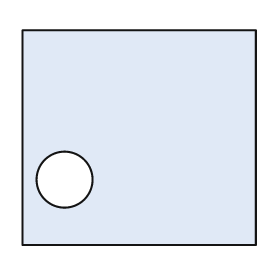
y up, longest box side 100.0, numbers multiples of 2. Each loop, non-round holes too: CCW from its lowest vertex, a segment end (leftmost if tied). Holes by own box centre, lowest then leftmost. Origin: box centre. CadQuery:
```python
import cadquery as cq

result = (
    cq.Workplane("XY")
    .moveTo(-50.0, -46.0)
    .lineTo(50.0, -46.0)
    .lineTo(50.0, 46.0)
    .lineTo(-50.0, 46.0)
    .close()
    .moveTo(-32.0, -18.0)
    .circle(12.0)
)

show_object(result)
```